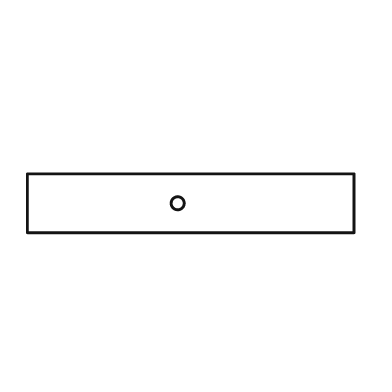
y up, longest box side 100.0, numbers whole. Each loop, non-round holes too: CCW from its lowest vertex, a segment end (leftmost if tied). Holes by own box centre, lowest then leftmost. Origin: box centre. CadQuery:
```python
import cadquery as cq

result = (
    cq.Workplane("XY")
    .moveTo(-50.0, -9.0)
    .lineTo(50.0, -9.0)
    .lineTo(50.0, 9.0)
    .lineTo(-50.0, 9.0)
    .close()
    .moveTo(-4.0, 0.0)
    .circle(2.0)
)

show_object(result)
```